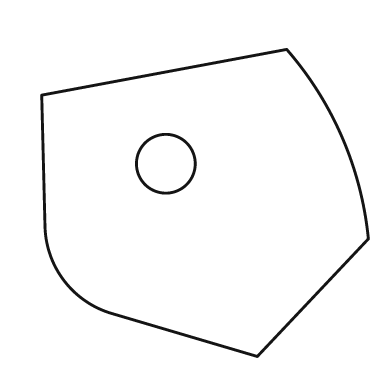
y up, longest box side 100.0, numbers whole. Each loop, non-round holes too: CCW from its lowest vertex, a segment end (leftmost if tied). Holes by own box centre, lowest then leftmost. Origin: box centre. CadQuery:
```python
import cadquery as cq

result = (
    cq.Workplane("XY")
    .moveTo(16.0, -47.0)
    .lineTo(50.0, -11.0)
    .threePointArc((42.0, 20.0), (25.0, 47.0))
    .lineTo(-50.0, 33.0)
    .lineTo(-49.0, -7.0)
    .threePointArc((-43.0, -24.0), (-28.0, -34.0))
    .close()
    .moveTo(-12.0, 12.0)
    .circle(9.0)
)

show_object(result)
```